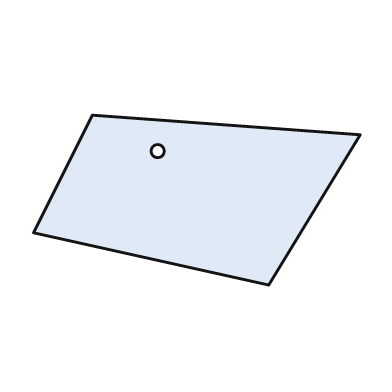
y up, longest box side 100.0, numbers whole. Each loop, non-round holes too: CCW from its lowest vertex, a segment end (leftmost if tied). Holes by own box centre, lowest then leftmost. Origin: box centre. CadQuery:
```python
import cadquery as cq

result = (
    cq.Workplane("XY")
    .moveTo(22.0, -26.0)
    .lineTo(50.0, 20.0)
    .lineTo(-32.0, 26.0)
    .lineTo(-50.0, -10.0)
    .close()
    .moveTo(-12.0, 15.0)
    .circle(2.0)
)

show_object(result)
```